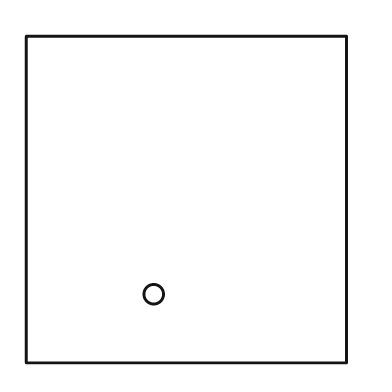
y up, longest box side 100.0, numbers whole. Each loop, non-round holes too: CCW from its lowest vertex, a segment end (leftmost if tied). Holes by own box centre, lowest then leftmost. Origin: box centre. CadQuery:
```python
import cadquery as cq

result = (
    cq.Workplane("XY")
    .moveTo(-49.0, -50.0)
    .lineTo(49.0, -50.0)
    .lineTo(49.0, 50.0)
    .lineTo(-49.0, 50.0)
    .close()
    .moveTo(-10.0, -29.0)
    .circle(3.0)
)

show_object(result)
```